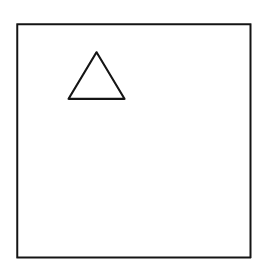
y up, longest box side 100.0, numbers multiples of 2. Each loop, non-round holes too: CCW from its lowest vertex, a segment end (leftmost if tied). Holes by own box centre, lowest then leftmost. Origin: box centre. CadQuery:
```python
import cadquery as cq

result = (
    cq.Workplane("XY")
    .moveTo(-50.0, -50.0)
    .lineTo(50.0, -50.0)
    .lineTo(50.0, 50.0)
    .lineTo(-50.0, 50.0)
    .close()
    .moveTo(-28.0, 18.0)
    .lineTo(-4.0, 18.0)
    .lineTo(-16.0, 38.0)
    .close()
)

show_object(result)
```